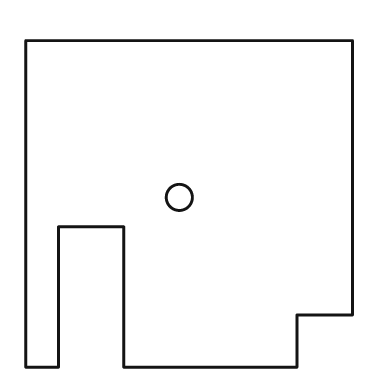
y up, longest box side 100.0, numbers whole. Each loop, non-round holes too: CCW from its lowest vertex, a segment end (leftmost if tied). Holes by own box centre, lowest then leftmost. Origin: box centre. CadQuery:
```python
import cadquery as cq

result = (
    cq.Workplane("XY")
    .moveTo(-50.0, -50.0)
    .lineTo(-40.0, -50.0)
    .lineTo(-40.0, -7.0)
    .lineTo(-20.0, -7.0)
    .lineTo(-20.0, -50.0)
    .lineTo(33.0, -50.0)
    .lineTo(33.0, -34.0)
    .lineTo(50.0, -34.0)
    .lineTo(50.0, 50.0)
    .lineTo(-50.0, 50.0)
    .close()
    .moveTo(-3.0, 2.0)
    .circle(4.0)
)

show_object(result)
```